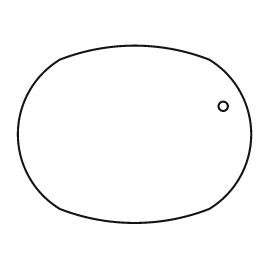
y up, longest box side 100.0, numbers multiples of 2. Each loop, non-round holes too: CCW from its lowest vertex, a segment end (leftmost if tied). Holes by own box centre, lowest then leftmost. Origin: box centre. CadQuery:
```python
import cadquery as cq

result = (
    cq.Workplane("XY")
    .moveTo(-32.0, -32.0)
    .threePointArc((0.0, -38.0), (32.0, -32.0))
    .threePointArc((50.0, 0.0), (32.0, 32.0))
    .threePointArc((0.0, 38.0), (-32.0, 32.0))
    .threePointArc((-50.0, 0.0), (-32.0, -32.0))
    .close()
    .moveTo(38.0, 12.0)
    .circle(2.0)
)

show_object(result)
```